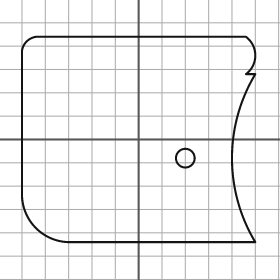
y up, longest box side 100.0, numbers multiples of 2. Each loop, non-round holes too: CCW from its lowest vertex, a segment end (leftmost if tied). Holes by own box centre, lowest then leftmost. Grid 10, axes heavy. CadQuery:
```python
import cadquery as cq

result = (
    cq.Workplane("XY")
    .moveTo(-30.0, -44.0)
    .lineTo(50.0, -44.0)
    .threePointArc((40.0, -8.0), (50.0, 28.0))
    .lineTo(46.0, 28.0)
    .threePointArc((50.0, 36.0), (46.0, 44.0))
    .lineTo(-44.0, 44.0)
    .threePointArc((-48.0, 42.0), (-50.0, 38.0))
    .lineTo(-50.0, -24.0)
    .threePointArc((-44.0, -38.0), (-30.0, -44.0))
    .close()
    .moveTo(20.0, -8.0)
    .circle(4.0)
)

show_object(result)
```